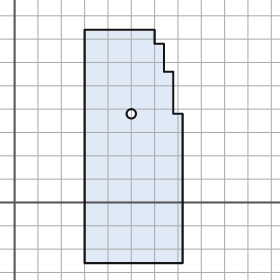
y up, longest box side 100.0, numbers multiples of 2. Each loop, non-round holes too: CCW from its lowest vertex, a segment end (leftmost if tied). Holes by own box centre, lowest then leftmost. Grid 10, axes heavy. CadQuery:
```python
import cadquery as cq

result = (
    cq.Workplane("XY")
    .moveTo(30.0, -26.0)
    .lineTo(72.0, -26.0)
    .lineTo(72.0, 38.0)
    .lineTo(68.0, 38.0)
    .lineTo(68.0, 56.0)
    .lineTo(64.0, 56.0)
    .lineTo(64.0, 68.0)
    .lineTo(60.0, 68.0)
    .lineTo(60.0, 74.0)
    .lineTo(30.0, 74.0)
    .close()
    .moveTo(50.0, 38.0)
    .circle(2.0)
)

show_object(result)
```